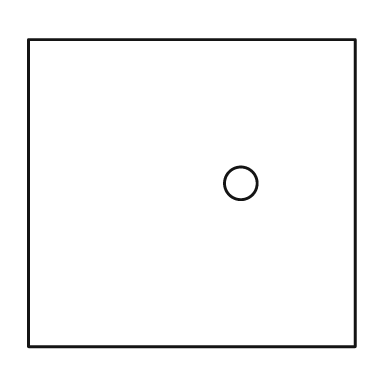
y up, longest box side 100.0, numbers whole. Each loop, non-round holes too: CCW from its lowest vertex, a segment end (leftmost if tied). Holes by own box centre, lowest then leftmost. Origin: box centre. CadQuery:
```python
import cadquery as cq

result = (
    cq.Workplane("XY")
    .moveTo(-50.0, -47.0)
    .lineTo(50.0, -47.0)
    .lineTo(50.0, 47.0)
    .lineTo(-50.0, 47.0)
    .close()
    .moveTo(15.0, 3.0)
    .circle(5.0)
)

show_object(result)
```